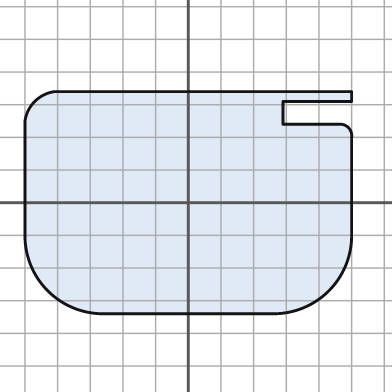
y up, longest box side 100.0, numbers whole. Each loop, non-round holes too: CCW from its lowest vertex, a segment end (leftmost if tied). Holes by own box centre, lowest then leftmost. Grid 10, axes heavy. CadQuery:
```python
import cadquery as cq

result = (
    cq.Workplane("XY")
    .moveTo(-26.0, -34.0)
    .lineTo(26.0, -34.0)
    .threePointArc((43.0, -27.0), (50.0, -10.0))
    .lineTo(50.0, 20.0)
    .threePointArc((49.0, 23.0), (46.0, 24.0))
    .lineTo(29.0, 24.0)
    .lineTo(29.0, 31.0)
    .lineTo(50.0, 31.0)
    .lineTo(50.0, 34.0)
    .lineTo(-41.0, 34.0)
    .threePointArc((-47.0, 31.0), (-50.0, 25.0))
    .lineTo(-50.0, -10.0)
    .threePointArc((-43.0, -27.0), (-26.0, -34.0))
    .close()
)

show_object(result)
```